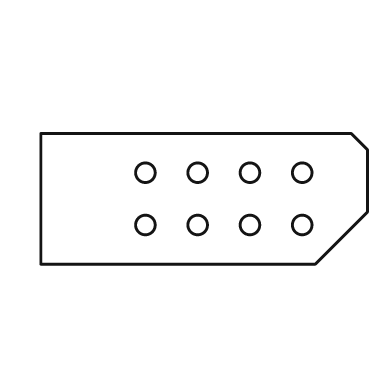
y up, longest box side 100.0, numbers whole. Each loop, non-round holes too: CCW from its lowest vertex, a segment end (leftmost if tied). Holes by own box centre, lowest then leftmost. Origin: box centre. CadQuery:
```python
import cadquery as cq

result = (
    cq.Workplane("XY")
    .moveTo(-50.0, -20.0)
    .lineTo(34.0, -20.0)
    .lineTo(50.0, -4.0)
    .lineTo(50.0, 15.0)
    .lineTo(45.0, 20.0)
    .lineTo(-50.0, 20.0)
    .close()
    .moveTo(-18.0, -8.0)
    .circle(3.0)
    .moveTo(-2.0, -8.0)
    .circle(3.0)
    .moveTo(14.0, -8.0)
    .circle(3.0)
    .moveTo(30.0, -8.0)
    .circle(3.0)
    .moveTo(-18.0, 8.0)
    .circle(3.0)
    .moveTo(-2.0, 8.0)
    .circle(3.0)
    .moveTo(14.0, 8.0)
    .circle(3.0)
    .moveTo(30.0, 8.0)
    .circle(3.0)
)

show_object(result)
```